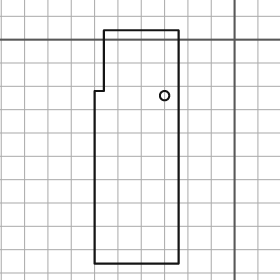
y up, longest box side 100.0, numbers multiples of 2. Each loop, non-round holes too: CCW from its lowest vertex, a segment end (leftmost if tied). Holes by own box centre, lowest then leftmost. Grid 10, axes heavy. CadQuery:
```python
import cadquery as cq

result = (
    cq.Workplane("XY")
    .moveTo(-60.0, -96.0)
    .lineTo(-24.0, -96.0)
    .lineTo(-24.0, 4.0)
    .lineTo(-56.0, 4.0)
    .lineTo(-56.0, -22.0)
    .lineTo(-60.0, -22.0)
    .close()
    .moveTo(-30.0, -24.0)
    .circle(2.0)
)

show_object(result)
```